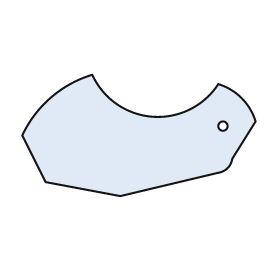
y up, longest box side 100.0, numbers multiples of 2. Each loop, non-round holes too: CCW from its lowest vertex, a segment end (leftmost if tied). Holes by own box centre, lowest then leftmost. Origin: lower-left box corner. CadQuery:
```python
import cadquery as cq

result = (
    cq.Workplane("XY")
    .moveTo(42.0, 0.0)
    .lineTo(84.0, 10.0)
    .threePointArc((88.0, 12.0), (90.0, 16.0))
    .lineTo(100.0, 32.0)
    .threePointArc((94.0, 42.0), (84.0, 48.0))
    .threePointArc((56.0, 34.0), (30.0, 52.0))
    .threePointArc((12.0, 42.0), (0.0, 26.0))
    .lineTo(10.0, 6.0)
    .close()
    .moveTo(86.0, 30.0)
    .circle(2.0)
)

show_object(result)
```